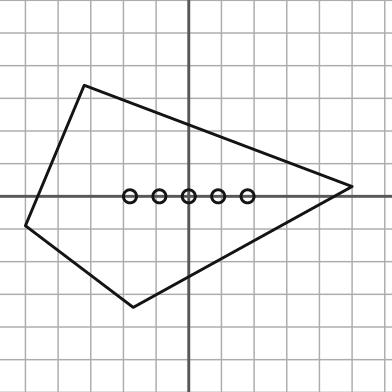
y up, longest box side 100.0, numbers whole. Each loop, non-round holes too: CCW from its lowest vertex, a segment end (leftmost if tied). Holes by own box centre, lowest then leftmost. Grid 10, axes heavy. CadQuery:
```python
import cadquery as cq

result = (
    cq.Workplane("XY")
    .moveTo(-17.0, -34.0)
    .lineTo(50.0, 3.0)
    .lineTo(-32.0, 34.0)
    .lineTo(-50.0, -9.0)
    .close()
    .moveTo(-18.0, 0.0)
    .circle(2.0)
    .moveTo(-9.0, 0.0)
    .circle(2.0)
    .moveTo(0.0, 0.0)
    .circle(2.0)
    .moveTo(9.0, 0.0)
    .circle(2.0)
    .moveTo(18.0, 0.0)
    .circle(2.0)
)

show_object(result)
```